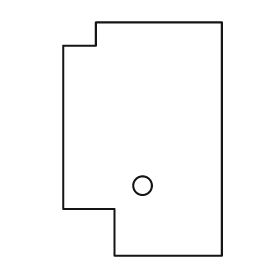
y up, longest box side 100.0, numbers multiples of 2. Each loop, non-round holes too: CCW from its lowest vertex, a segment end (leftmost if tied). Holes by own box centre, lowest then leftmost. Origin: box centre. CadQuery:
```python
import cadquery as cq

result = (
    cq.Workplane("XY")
    .moveTo(-12.0, -50.0)
    .lineTo(34.0, -50.0)
    .lineTo(34.0, 50.0)
    .lineTo(-20.0, 50.0)
    .lineTo(-20.0, 40.0)
    .lineTo(-34.0, 40.0)
    .lineTo(-34.0, -30.0)
    .lineTo(-12.0, -30.0)
    .close()
    .moveTo(0.0, -20.0)
    .circle(4.0)
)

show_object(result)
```